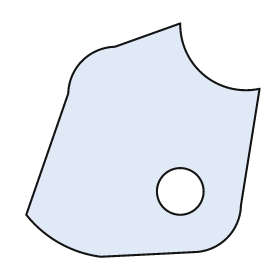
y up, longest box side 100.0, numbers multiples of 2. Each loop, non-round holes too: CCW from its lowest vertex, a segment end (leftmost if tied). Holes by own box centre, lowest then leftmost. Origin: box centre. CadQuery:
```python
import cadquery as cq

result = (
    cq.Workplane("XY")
    .moveTo(-18.0, -50.0)
    .lineTo(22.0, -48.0)
    .threePointArc((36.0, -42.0), (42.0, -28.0))
    .lineTo(50.0, 22.0)
    .threePointArc((26.0, 28.0), (16.0, 50.0))
    .lineTo(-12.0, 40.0)
    .threePointArc((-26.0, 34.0), (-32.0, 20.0))
    .lineTo(-50.0, -32.0)
    .threePointArc((-36.0, -44.0), (-18.0, -50.0))
    .close()
    .moveTo(16.0, -22.0)
    .circle(10.0)
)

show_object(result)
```